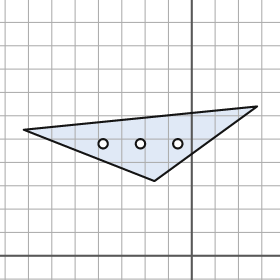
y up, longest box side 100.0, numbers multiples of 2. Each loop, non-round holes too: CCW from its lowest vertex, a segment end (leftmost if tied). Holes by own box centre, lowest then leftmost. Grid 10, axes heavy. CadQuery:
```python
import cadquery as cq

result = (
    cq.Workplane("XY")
    .moveTo(-16.0, 32.0)
    .lineTo(28.0, 64.0)
    .lineTo(-72.0, 54.0)
    .close()
    .moveTo(-38.0, 48.0)
    .circle(2.0)
    .moveTo(-22.0, 48.0)
    .circle(2.0)
    .moveTo(-6.0, 48.0)
    .circle(2.0)
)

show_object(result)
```